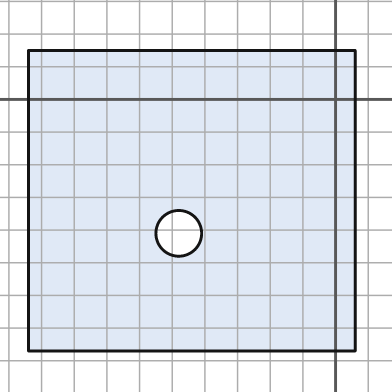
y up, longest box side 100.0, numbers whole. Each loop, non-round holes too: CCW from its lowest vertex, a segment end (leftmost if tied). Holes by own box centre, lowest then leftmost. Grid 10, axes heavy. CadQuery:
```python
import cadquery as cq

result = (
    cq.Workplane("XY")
    .moveTo(-94.0, -77.0)
    .lineTo(6.0, -77.0)
    .lineTo(6.0, 15.0)
    .lineTo(-94.0, 15.0)
    .close()
    .moveTo(-48.0, -41.0)
    .circle(7.0)
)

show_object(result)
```